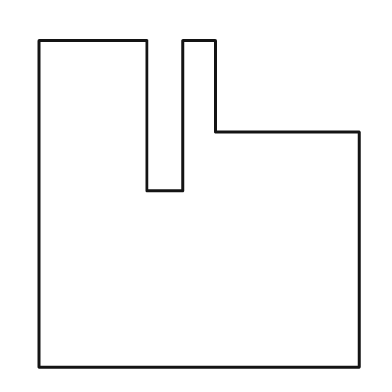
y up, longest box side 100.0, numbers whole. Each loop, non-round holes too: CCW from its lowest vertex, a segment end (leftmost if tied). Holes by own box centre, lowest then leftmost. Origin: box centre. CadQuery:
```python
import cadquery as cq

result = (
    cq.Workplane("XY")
    .moveTo(-49.0, -50.0)
    .lineTo(49.0, -50.0)
    .lineTo(49.0, 22.0)
    .lineTo(5.0, 22.0)
    .lineTo(5.0, 50.0)
    .lineTo(-5.0, 50.0)
    .lineTo(-5.0, 4.0)
    .lineTo(-16.0, 4.0)
    .lineTo(-16.0, 50.0)
    .lineTo(-49.0, 50.0)
    .close()
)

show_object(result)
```